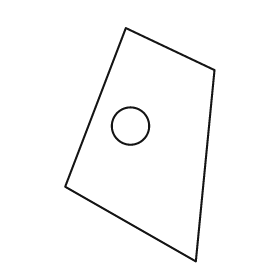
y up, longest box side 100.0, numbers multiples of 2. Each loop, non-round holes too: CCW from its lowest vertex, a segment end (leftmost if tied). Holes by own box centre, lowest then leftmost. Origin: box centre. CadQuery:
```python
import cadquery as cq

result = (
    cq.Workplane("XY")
    .moveTo(24.0, -50.0)
    .lineTo(32.0, 32.0)
    .lineTo(-6.0, 50.0)
    .lineTo(-32.0, -18.0)
    .close()
    .moveTo(-4.0, 8.0)
    .circle(8.0)
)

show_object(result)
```